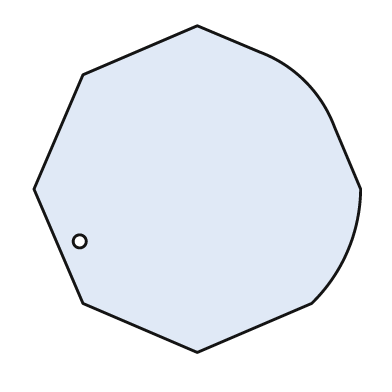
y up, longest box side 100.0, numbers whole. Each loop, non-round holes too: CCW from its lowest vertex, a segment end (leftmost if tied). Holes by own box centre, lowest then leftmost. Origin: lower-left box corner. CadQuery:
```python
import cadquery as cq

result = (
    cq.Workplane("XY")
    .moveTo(50.0, 0.0)
    .lineTo(85.0, 15.0)
    .threePointArc((96.0, 31.0), (100.0, 50.0))
    .lineTo(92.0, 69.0)
    .threePointArc((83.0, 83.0), (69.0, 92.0))
    .lineTo(50.0, 100.0)
    .lineTo(15.0, 85.0)
    .lineTo(0.0, 50.0)
    .lineTo(15.0, 15.0)
    .close()
    .moveTo(14.0, 34.0)
    .circle(2.0)
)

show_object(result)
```